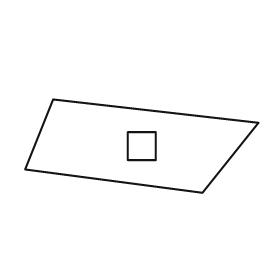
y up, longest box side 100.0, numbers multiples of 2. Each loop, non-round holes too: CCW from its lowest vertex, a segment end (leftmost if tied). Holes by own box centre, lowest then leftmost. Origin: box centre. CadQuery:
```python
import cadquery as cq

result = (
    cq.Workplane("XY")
    .moveTo(26.0, -20.0)
    .lineTo(50.0, 10.0)
    .lineTo(-38.0, 20.0)
    .lineTo(-50.0, -10.0)
    .close()
    .moveTo(-6.0, -6.0)
    .lineTo(6.0, -6.0)
    .lineTo(6.0, 6.0)
    .lineTo(-6.0, 6.0)
    .close()
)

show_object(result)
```